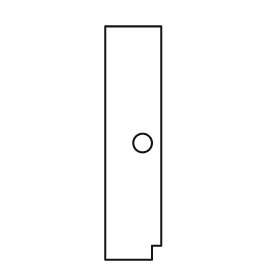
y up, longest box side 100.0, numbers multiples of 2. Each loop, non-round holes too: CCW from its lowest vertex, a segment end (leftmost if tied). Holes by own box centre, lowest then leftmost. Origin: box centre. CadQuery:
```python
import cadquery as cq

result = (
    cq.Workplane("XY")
    .moveTo(-12.0, -50.0)
    .lineTo(8.0, -50.0)
    .lineTo(8.0, -44.0)
    .lineTo(12.0, -44.0)
    .lineTo(12.0, 50.0)
    .lineTo(-12.0, 50.0)
    .close()
    .moveTo(4.0, 0.0)
    .circle(4.0)
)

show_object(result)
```